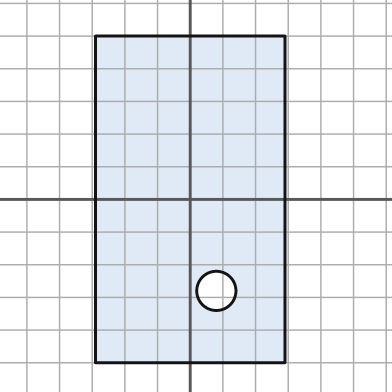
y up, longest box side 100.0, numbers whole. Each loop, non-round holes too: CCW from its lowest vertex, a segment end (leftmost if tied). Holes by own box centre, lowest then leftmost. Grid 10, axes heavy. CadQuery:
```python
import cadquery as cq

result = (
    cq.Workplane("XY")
    .moveTo(-29.0, -50.0)
    .lineTo(29.0, -50.0)
    .lineTo(29.0, 50.0)
    .lineTo(-29.0, 50.0)
    .close()
    .moveTo(8.0, -28.0)
    .circle(6.0)
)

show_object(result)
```